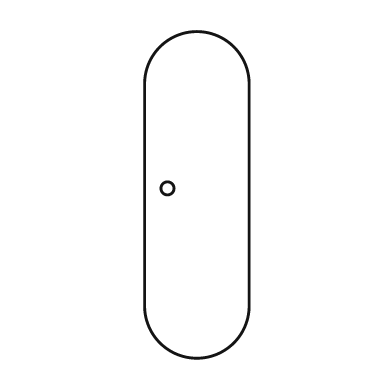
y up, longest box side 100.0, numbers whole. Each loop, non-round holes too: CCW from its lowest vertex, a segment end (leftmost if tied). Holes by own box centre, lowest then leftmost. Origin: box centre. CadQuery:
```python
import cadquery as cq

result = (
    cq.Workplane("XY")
    .moveTo(-16.0, -34.0)
    .threePointArc((0.0, -50.0), (16.0, -34.0))
    .lineTo(16.0, 34.0)
    .threePointArc((0.0, 50.0), (-16.0, 34.0))
    .close()
    .moveTo(-9.0, 2.0)
    .circle(2.0)
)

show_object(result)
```